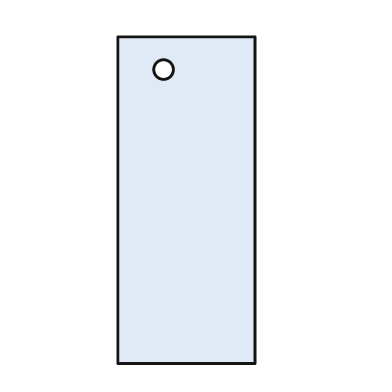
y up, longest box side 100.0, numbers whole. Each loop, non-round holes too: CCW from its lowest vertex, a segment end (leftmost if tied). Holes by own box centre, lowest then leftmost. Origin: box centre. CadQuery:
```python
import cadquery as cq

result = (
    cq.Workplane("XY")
    .moveTo(-21.0, -50.0)
    .lineTo(21.0, -50.0)
    .lineTo(21.0, 50.0)
    .lineTo(-21.0, 50.0)
    .close()
    .moveTo(-7.0, 40.0)
    .circle(3.0)
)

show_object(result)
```